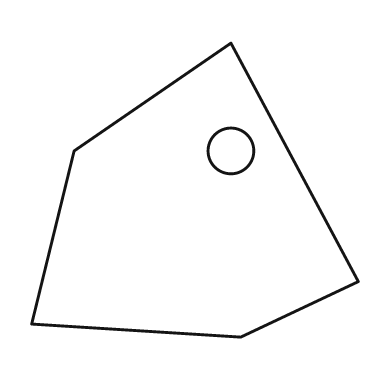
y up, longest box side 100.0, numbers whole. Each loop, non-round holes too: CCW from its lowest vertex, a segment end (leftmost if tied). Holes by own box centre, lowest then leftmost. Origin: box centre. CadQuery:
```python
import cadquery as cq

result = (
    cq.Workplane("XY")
    .moveTo(14.0, -45.0)
    .lineTo(50.0, -28.0)
    .lineTo(11.0, 45.0)
    .lineTo(-37.0, 12.0)
    .lineTo(-50.0, -41.0)
    .close()
    .moveTo(11.0, 12.0)
    .circle(7.0)
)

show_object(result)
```